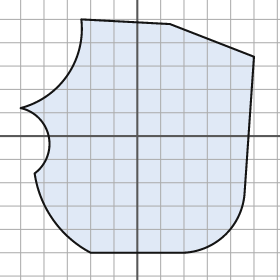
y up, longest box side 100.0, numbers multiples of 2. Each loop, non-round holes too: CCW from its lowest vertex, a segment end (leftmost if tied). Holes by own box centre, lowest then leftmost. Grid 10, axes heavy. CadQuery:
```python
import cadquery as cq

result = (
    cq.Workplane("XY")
    .moveTo(-20.0, -50.0)
    .lineTo(20.0, -50.0)
    .threePointArc((38.0, -42.0), (46.0, -24.0))
    .lineTo(50.0, 34.0)
    .lineTo(14.0, 48.0)
    .lineTo(-24.0, 50.0)
    .threePointArc((-30.0, 26.0), (-50.0, 12.0))
    .threePointArc((-38.0, 0.0), (-44.0, -16.0))
    .threePointArc((-36.0, -36.0), (-20.0, -50.0))
    .close()
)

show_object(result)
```